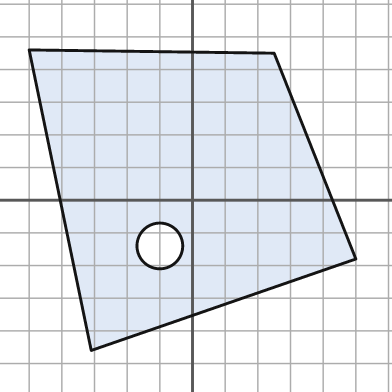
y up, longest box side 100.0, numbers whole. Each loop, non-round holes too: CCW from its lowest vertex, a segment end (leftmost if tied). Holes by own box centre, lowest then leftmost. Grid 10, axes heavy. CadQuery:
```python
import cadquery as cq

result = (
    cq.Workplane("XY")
    .moveTo(-31.0, -46.0)
    .lineTo(50.0, -18.0)
    .lineTo(25.0, 45.0)
    .lineTo(-50.0, 46.0)
    .close()
    .moveTo(-10.0, -14.0)
    .circle(7.0)
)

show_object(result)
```